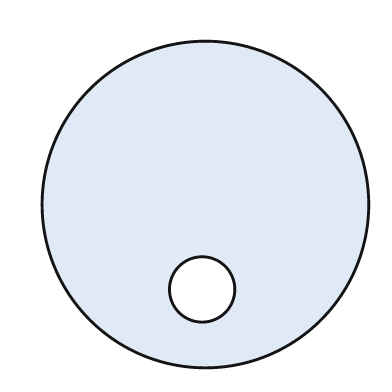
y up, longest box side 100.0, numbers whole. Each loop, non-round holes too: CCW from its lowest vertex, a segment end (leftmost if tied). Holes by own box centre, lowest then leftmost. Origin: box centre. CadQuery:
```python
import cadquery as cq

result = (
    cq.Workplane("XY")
    .moveTo(0.0, 0.0)
    .circle(50.0)
    .moveTo(-1.0, -26.0)
    .circle(10.0)
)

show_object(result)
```